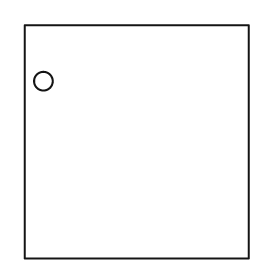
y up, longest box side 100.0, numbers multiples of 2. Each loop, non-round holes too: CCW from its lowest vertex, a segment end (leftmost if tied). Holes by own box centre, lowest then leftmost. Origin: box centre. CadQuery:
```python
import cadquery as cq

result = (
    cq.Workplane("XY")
    .moveTo(-48.0, -50.0)
    .lineTo(48.0, -50.0)
    .lineTo(48.0, 50.0)
    .lineTo(-48.0, 50.0)
    .close()
    .moveTo(-40.0, 26.0)
    .circle(4.0)
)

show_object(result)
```